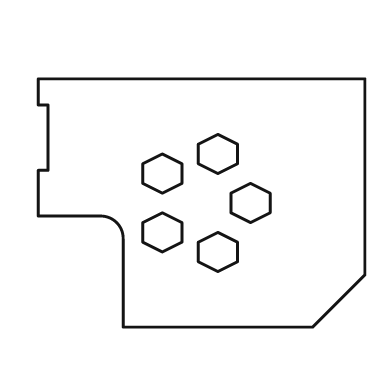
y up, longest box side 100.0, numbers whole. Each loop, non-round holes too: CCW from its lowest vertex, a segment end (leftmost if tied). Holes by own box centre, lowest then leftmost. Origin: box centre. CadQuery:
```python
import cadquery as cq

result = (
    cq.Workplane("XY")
    .moveTo(-24.0, -38.0)
    .lineTo(34.0, -38.0)
    .lineTo(50.0, -22.0)
    .lineTo(50.0, 38.0)
    .lineTo(-50.0, 38.0)
    .lineTo(-50.0, 30.0)
    .lineTo(-47.0, 30.0)
    .lineTo(-47.0, 10.0)
    .lineTo(-50.0, 10.0)
    .lineTo(-50.0, -4.0)
    .lineTo(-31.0, -4.0)
    .threePointArc((-26.0, -6.0), (-24.0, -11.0))
    .close()
    .moveTo(5.0, -21.0)
    .lineTo(11.0, -18.0)
    .lineTo(11.0, -12.0)
    .lineTo(5.0, -9.0)
    .lineTo(-1.0, -12.0)
    .lineTo(-1.0, -18.0)
    .close()
    .moveTo(-12.0, -15.0)
    .lineTo(-6.0, -12.0)
    .lineTo(-6.0, -6.0)
    .lineTo(-12.0, -3.0)
    .lineTo(-18.0, -6.0)
    .lineTo(-18.0, -12.0)
    .close()
    .moveTo(15.0, -6.0)
    .lineTo(21.0, -3.0)
    .lineTo(21.0, 3.0)
    .lineTo(15.0, 6.0)
    .lineTo(9.0, 3.0)
    .lineTo(9.0, -3.0)
    .close()
    .moveTo(-12.0, 3.0)
    .lineTo(-6.0, 6.0)
    .lineTo(-6.0, 12.0)
    .lineTo(-12.0, 15.0)
    .lineTo(-18.0, 12.0)
    .lineTo(-18.0, 6.0)
    .close()
    .moveTo(5.0, 9.0)
    .lineTo(11.0, 12.0)
    .lineTo(11.0, 18.0)
    .lineTo(5.0, 21.0)
    .lineTo(-1.0, 18.0)
    .lineTo(-1.0, 12.0)
    .close()
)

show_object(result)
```